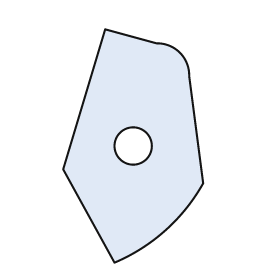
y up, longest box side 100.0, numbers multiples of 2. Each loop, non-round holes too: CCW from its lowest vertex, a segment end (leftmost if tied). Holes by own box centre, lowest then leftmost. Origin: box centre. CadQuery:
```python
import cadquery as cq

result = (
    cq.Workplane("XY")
    .moveTo(-8.0, -50.0)
    .threePointArc((14.0, -36.0), (30.0, -16.0))
    .lineTo(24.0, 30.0)
    .threePointArc((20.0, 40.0), (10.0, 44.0))
    .lineTo(-12.0, 50.0)
    .lineTo(-30.0, -10.0)
    .close()
    .moveTo(0.0, 0.0)
    .circle(8.0)
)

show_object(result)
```